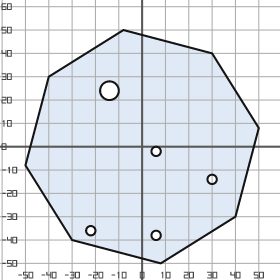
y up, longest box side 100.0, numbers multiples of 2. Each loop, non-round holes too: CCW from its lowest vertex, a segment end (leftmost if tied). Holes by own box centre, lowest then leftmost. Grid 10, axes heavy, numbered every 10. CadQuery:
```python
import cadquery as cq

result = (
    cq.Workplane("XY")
    .moveTo(8.0, -50.0)
    .lineTo(40.0, -30.0)
    .lineTo(50.0, 8.0)
    .lineTo(30.0, 40.0)
    .lineTo(-8.0, 50.0)
    .lineTo(-40.0, 30.0)
    .lineTo(-50.0, -8.0)
    .lineTo(-30.0, -40.0)
    .close()
    .moveTo(6.0, -38.0)
    .circle(2.0)
    .moveTo(-22.0, -36.0)
    .circle(2.0)
    .moveTo(30.0, -14.0)
    .circle(2.0)
    .moveTo(6.0, -2.0)
    .circle(2.0)
    .moveTo(-14.0, 24.0)
    .circle(4.0)
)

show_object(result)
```